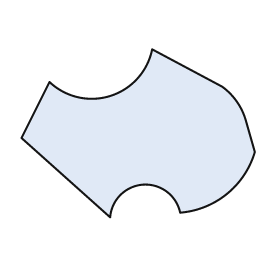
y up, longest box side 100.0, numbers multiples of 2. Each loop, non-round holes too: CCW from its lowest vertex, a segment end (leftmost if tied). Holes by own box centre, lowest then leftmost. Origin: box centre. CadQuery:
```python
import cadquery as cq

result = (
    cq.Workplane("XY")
    .moveTo(-12.0, -36.0)
    .threePointArc((2.0, -22.0), (18.0, -34.0))
    .threePointArc((38.0, -26.0), (50.0, -8.0))
    .lineTo(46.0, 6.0)
    .threePointArc((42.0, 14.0), (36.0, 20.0))
    .lineTo(6.0, 36.0)
    .threePointArc((-12.0, 16.0), (-38.0, 22.0))
    .lineTo(-50.0, -2.0)
    .close()
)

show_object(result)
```